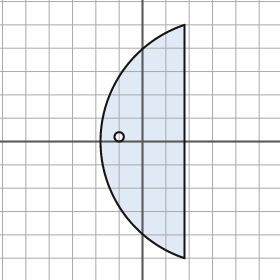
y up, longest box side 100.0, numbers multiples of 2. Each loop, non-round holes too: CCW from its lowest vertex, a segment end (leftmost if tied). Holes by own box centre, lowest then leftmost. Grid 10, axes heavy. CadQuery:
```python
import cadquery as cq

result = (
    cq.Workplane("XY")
    .moveTo(18.0, -50.0)
    .lineTo(18.0, 50.0)
    .threePointArc((-18.0, 0.0), (18.0, -50.0))
    .close()
    .moveTo(-10.0, 2.0)
    .circle(2.0)
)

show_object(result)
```